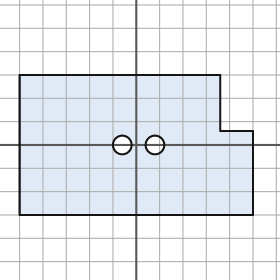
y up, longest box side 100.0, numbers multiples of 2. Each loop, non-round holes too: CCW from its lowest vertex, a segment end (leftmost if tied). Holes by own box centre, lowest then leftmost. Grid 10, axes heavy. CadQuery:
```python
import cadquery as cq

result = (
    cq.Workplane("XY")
    .moveTo(-50.0, -30.0)
    .lineTo(50.0, -30.0)
    .lineTo(50.0, 6.0)
    .lineTo(36.0, 6.0)
    .lineTo(36.0, 30.0)
    .lineTo(-50.0, 30.0)
    .close()
    .moveTo(-6.0, 0.0)
    .circle(4.0)
    .moveTo(8.0, 0.0)
    .circle(4.0)
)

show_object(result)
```